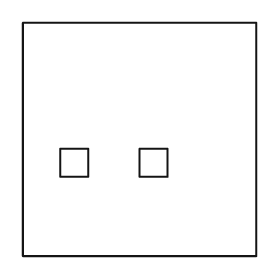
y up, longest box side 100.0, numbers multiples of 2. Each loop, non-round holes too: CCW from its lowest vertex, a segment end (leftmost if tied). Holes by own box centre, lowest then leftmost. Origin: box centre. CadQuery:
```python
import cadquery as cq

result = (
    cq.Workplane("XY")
    .moveTo(-50.0, -50.0)
    .lineTo(50.0, -50.0)
    .lineTo(50.0, 50.0)
    .lineTo(-50.0, 50.0)
    .close()
    .moveTo(-34.0, -16.0)
    .lineTo(-22.0, -16.0)
    .lineTo(-22.0, -4.0)
    .lineTo(-34.0, -4.0)
    .close()
    .moveTo(0.0, -16.0)
    .lineTo(12.0, -16.0)
    .lineTo(12.0, -4.0)
    .lineTo(0.0, -4.0)
    .close()
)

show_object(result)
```